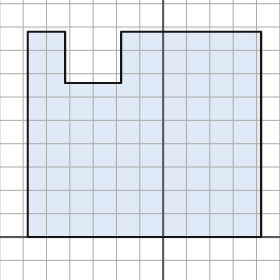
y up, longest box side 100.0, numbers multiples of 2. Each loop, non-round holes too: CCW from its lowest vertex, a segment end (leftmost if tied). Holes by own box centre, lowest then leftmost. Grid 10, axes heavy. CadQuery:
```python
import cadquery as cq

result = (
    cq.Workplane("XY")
    .moveTo(-58.0, 0.0)
    .lineTo(42.0, 0.0)
    .lineTo(42.0, 88.0)
    .lineTo(-18.0, 88.0)
    .lineTo(-18.0, 66.0)
    .lineTo(-42.0, 66.0)
    .lineTo(-42.0, 88.0)
    .lineTo(-58.0, 88.0)
    .close()
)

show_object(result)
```